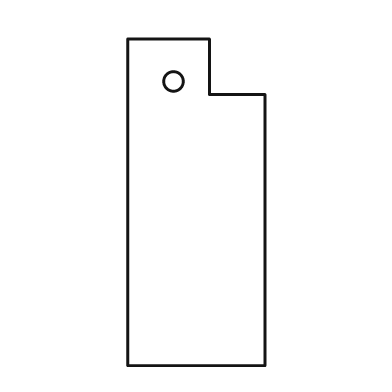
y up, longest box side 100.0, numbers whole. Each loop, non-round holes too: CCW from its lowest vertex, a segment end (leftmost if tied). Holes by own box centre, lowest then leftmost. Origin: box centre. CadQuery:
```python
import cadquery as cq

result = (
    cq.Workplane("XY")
    .moveTo(-21.0, -50.0)
    .lineTo(21.0, -50.0)
    .lineTo(21.0, 33.0)
    .lineTo(4.0, 33.0)
    .lineTo(4.0, 50.0)
    .lineTo(-21.0, 50.0)
    .close()
    .moveTo(-7.0, 37.0)
    .circle(3.0)
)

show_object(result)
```